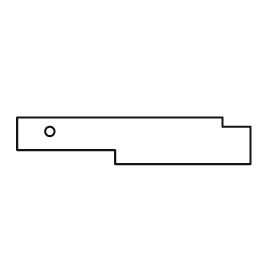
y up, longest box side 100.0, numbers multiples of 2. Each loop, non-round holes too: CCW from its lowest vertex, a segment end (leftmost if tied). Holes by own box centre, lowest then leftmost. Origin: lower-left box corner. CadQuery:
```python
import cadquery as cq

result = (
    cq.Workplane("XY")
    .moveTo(42.0, 0.0)
    .lineTo(100.0, 0.0)
    .lineTo(100.0, 16.0)
    .lineTo(88.0, 16.0)
    .lineTo(88.0, 20.0)
    .lineTo(0.0, 20.0)
    .lineTo(0.0, 6.0)
    .lineTo(42.0, 6.0)
    .close()
    .moveTo(14.0, 14.0)
    .circle(2.0)
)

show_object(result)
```